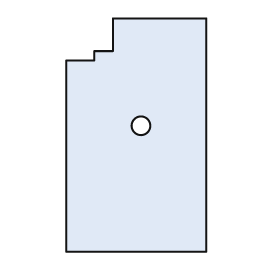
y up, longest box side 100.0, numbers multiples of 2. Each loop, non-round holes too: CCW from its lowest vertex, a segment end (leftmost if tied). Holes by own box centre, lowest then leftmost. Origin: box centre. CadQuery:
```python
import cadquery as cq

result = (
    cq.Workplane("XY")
    .moveTo(-30.0, -50.0)
    .lineTo(30.0, -50.0)
    .lineTo(30.0, 50.0)
    .lineTo(-10.0, 50.0)
    .lineTo(-10.0, 36.0)
    .lineTo(-18.0, 36.0)
    .lineTo(-18.0, 32.0)
    .lineTo(-30.0, 32.0)
    .close()
    .moveTo(2.0, 4.0)
    .circle(4.0)
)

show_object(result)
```